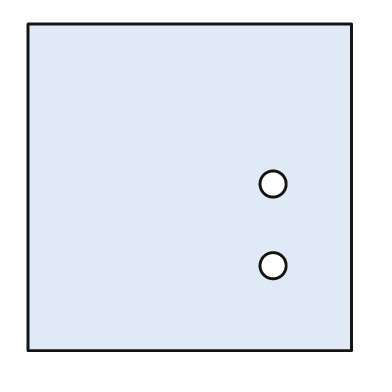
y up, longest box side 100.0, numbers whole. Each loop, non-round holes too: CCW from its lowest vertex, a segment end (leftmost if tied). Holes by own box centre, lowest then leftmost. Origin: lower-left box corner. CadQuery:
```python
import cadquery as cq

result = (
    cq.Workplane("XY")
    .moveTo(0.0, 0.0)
    .lineTo(99.0, 0.0)
    .lineTo(99.0, 100.0)
    .lineTo(0.0, 100.0)
    .close()
    .moveTo(75.0, 26.0)
    .circle(4.0)
    .moveTo(75.0, 51.0)
    .circle(4.0)
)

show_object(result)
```